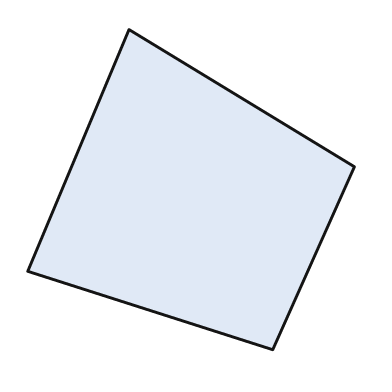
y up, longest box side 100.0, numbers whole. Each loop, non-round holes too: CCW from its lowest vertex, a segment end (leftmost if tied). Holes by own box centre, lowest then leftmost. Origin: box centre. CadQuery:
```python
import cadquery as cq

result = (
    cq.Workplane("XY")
    .moveTo(25.0, -49.0)
    .lineTo(50.0, 7.0)
    .lineTo(-19.0, 49.0)
    .lineTo(-50.0, -25.0)
    .close()
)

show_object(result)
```